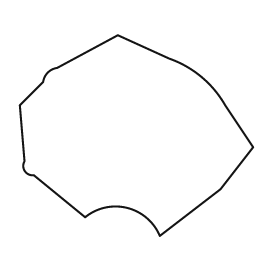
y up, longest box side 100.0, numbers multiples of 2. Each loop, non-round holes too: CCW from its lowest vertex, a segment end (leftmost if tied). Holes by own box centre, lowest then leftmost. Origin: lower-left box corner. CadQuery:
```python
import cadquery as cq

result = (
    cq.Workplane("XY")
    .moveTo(60.0, 0.0)
    .lineTo(86.0, 20.0)
    .lineTo(100.0, 38.0)
    .lineTo(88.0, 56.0)
    .threePointArc((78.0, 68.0), (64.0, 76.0))
    .lineTo(42.0, 86.0)
    .lineTo(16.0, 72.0)
    .threePointArc((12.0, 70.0), (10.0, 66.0))
    .lineTo(0.0, 56.0)
    .lineTo(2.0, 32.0)
    .threePointArc((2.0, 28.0), (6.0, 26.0))
    .lineTo(28.0, 8.0)
    .threePointArc((46.0, 12.0), (60.0, 0.0))
    .close()
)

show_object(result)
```